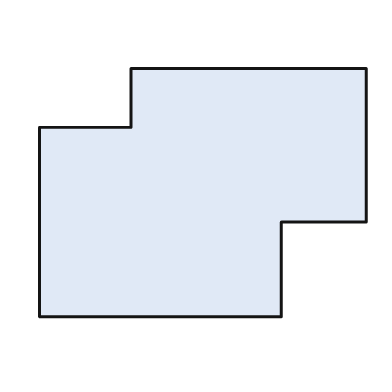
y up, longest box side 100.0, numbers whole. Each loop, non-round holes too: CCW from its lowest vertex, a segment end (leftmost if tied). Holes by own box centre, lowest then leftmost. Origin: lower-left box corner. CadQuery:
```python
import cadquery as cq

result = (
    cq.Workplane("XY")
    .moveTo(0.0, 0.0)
    .lineTo(74.0, 0.0)
    .lineTo(74.0, 29.0)
    .lineTo(100.0, 29.0)
    .lineTo(100.0, 76.0)
    .lineTo(28.0, 76.0)
    .lineTo(28.0, 58.0)
    .lineTo(0.0, 58.0)
    .close()
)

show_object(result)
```